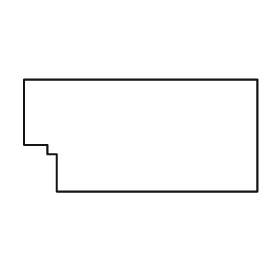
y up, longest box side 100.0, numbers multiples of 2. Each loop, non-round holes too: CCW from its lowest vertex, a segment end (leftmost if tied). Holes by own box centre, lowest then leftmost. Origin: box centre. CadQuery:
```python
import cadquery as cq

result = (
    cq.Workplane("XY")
    .moveTo(-36.0, -24.0)
    .lineTo(50.0, -24.0)
    .lineTo(50.0, 24.0)
    .lineTo(-50.0, 24.0)
    .lineTo(-50.0, -4.0)
    .lineTo(-40.0, -4.0)
    .lineTo(-40.0, -8.0)
    .lineTo(-36.0, -8.0)
    .close()
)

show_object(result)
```